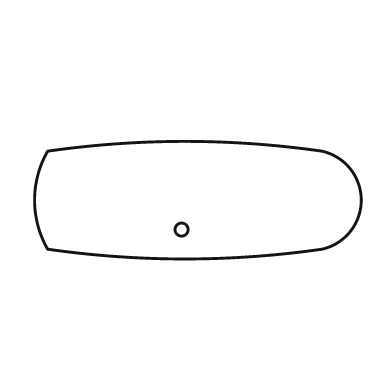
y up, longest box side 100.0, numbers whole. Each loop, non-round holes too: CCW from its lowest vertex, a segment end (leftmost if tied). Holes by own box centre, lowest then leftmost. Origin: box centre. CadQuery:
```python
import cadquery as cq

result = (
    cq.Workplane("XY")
    .moveTo(-46.0, -15.0)
    .threePointArc((-4.0, -18.0), (38.0, -15.0))
    .threePointArc((50.0, 0.0), (38.0, 15.0))
    .threePointArc((-4.0, 18.0), (-46.0, 15.0))
    .threePointArc((-50.0, 0.0), (-46.0, -15.0))
    .close()
    .moveTo(-5.0, -9.0)
    .circle(2.0)
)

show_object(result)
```